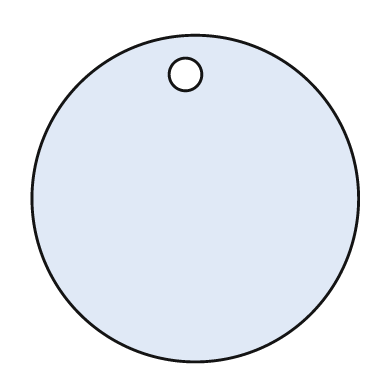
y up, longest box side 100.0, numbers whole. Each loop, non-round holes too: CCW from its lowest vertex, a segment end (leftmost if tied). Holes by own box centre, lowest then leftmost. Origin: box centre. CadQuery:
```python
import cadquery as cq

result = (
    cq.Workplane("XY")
    .moveTo(0.0, 0.0)
    .circle(50.0)
    .moveTo(-3.0, 38.0)
    .circle(5.0)
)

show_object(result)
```